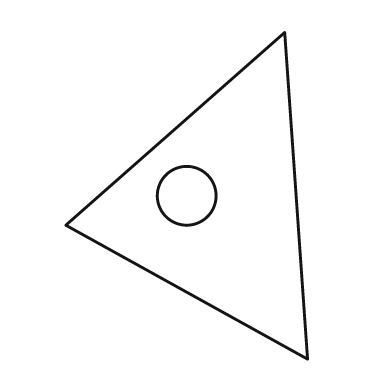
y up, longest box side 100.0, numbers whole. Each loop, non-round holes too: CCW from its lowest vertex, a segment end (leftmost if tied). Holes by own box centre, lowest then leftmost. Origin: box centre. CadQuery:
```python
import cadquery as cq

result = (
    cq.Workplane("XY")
    .moveTo(37.0, -50.0)
    .lineTo(30.0, 50.0)
    .lineTo(-37.0, -9.0)
    .close()
    .moveTo(0.0, 0.0)
    .circle(9.0)
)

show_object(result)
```